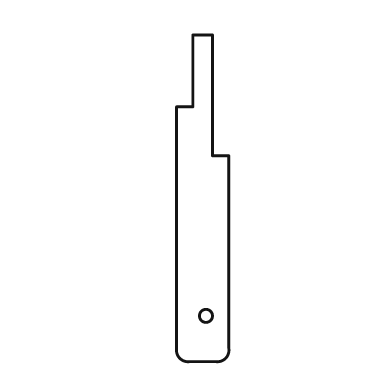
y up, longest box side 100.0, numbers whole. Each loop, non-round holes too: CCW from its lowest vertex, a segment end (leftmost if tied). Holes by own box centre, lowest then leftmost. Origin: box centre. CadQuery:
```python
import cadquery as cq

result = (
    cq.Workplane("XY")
    .moveTo(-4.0, -50.0)
    .lineTo(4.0, -50.0)
    .threePointArc((7.0, -49.0), (8.0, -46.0))
    .lineTo(8.0, 13.0)
    .lineTo(3.0, 13.0)
    .lineTo(3.0, 50.0)
    .lineTo(-3.0, 50.0)
    .lineTo(-3.0, 28.0)
    .lineTo(-8.0, 28.0)
    .lineTo(-8.0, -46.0)
    .threePointArc((-7.0, -49.0), (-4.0, -50.0))
    .close()
    .moveTo(1.0, -36.0)
    .circle(2.0)
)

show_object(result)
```